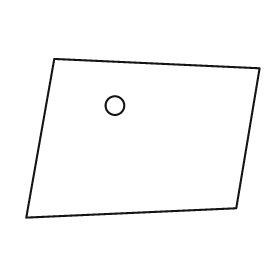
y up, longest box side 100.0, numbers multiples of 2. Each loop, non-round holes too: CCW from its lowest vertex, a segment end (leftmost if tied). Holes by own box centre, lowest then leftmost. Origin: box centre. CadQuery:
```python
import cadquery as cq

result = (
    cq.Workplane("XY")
    .moveTo(-50.0, -34.0)
    .lineTo(40.0, -30.0)
    .lineTo(50.0, 30.0)
    .lineTo(-38.0, 34.0)
    .close()
    .moveTo(-12.0, 14.0)
    .circle(4.0)
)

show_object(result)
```